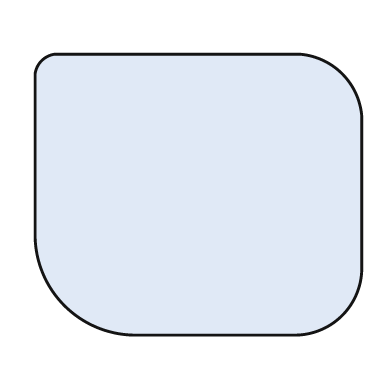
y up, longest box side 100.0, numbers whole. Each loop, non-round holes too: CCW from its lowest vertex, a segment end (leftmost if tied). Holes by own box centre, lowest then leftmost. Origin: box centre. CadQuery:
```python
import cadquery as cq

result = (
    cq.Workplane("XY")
    .moveTo(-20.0, -43.0)
    .lineTo(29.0, -43.0)
    .threePointArc((44.0, -37.0), (50.0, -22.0))
    .lineTo(50.0, 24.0)
    .threePointArc((44.0, 37.0), (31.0, 43.0))
    .lineTo(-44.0, 43.0)
    .threePointArc((-48.0, 41.0), (-50.0, 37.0))
    .lineTo(-50.0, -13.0)
    .threePointArc((-41.0, -34.0), (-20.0, -43.0))
    .close()
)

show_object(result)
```